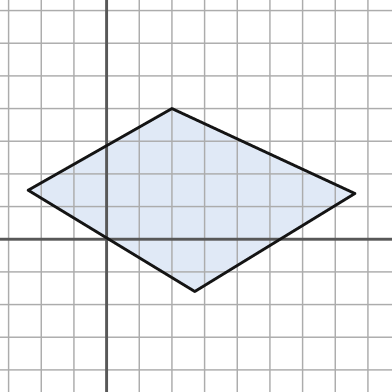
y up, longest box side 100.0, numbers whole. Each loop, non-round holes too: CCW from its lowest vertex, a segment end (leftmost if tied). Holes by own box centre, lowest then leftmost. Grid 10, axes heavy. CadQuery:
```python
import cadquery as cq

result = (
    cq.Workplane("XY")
    .moveTo(27.0, -16.0)
    .lineTo(76.0, 14.0)
    .lineTo(20.0, 40.0)
    .lineTo(-24.0, 15.0)
    .close()
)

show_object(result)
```